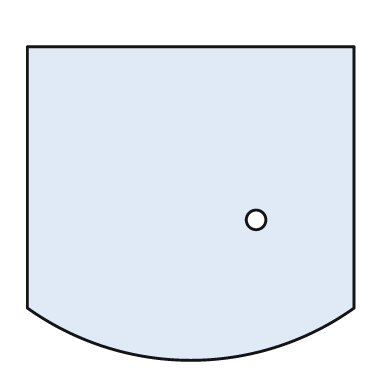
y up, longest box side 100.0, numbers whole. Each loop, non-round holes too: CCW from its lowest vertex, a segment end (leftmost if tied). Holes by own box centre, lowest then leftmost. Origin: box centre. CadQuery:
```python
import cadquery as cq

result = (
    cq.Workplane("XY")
    .moveTo(-50.0, -32.0)
    .threePointArc((0.0, -48.0), (50.0, -32.0))
    .lineTo(50.0, 48.0)
    .lineTo(-50.0, 48.0)
    .close()
    .moveTo(20.0, -5.0)
    .circle(3.0)
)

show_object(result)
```